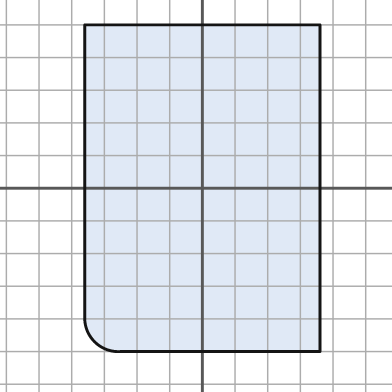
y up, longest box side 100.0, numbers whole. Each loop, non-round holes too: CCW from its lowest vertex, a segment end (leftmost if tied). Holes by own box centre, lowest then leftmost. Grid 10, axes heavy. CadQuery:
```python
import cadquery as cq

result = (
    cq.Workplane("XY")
    .moveTo(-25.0, -50.0)
    .lineTo(36.0, -50.0)
    .lineTo(36.0, 50.0)
    .lineTo(-36.0, 50.0)
    .lineTo(-36.0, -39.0)
    .threePointArc((-33.0, -47.0), (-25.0, -50.0))
    .close()
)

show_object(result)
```